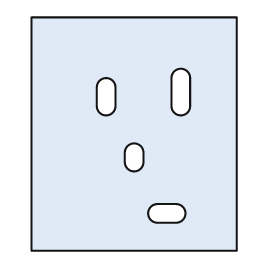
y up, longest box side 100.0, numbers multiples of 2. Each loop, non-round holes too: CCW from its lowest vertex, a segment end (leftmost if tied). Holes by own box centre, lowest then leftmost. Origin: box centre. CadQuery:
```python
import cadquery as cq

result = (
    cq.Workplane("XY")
    .moveTo(-44.0, -50.0)
    .lineTo(44.0, -50.0)
    .lineTo(44.0, 50.0)
    .lineTo(-44.0, 50.0)
    .close()
    .moveTo(10.0, -38.0)
    .lineTo(18.0, -38.0)
    .threePointArc((22.0, -34.0), (18.0, -30.0))
    .lineTo(10.0, -30.0)
    .threePointArc((6.0, -34.0), (10.0, -38.0))
    .close()
    .moveTo(-4.0, -12.0)
    .threePointArc((0.0, -16.0), (4.0, -12.0))
    .lineTo(4.0, -8.0)
    .threePointArc((0.0, -4.0), (-4.0, -8.0))
    .close()
    .moveTo(-16.0, 12.0)
    .threePointArc((-12.0, 8.0), (-8.0, 12.0))
    .lineTo(-8.0, 20.0)
    .threePointArc((-12.0, 24.0), (-16.0, 20.0))
    .close()
    .moveTo(16.0, 12.0)
    .threePointArc((20.0, 8.0), (24.0, 12.0))
    .lineTo(24.0, 24.0)
    .threePointArc((20.0, 28.0), (16.0, 24.0))
    .close()
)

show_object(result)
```